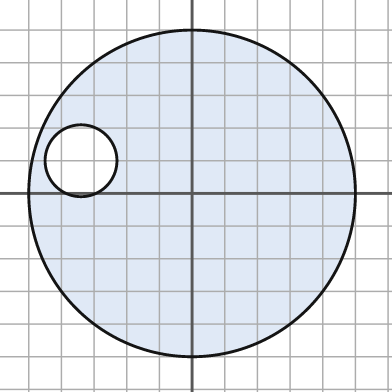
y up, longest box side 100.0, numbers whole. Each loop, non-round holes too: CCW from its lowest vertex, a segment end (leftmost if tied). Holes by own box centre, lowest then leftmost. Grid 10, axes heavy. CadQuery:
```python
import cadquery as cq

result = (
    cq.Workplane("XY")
    .moveTo(0.0, 0.0)
    .circle(50.0)
    .moveTo(-34.0, 10.0)
    .circle(11.0)
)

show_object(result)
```